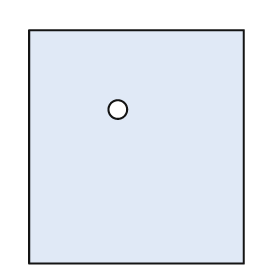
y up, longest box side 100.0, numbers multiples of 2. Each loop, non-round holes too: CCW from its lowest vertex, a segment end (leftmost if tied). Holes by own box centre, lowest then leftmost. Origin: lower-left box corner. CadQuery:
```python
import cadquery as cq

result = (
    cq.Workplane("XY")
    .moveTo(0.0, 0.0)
    .lineTo(92.0, 0.0)
    .lineTo(92.0, 100.0)
    .lineTo(0.0, 100.0)
    .close()
    .moveTo(38.0, 66.0)
    .circle(4.0)
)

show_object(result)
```